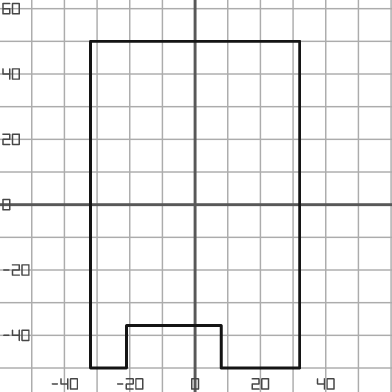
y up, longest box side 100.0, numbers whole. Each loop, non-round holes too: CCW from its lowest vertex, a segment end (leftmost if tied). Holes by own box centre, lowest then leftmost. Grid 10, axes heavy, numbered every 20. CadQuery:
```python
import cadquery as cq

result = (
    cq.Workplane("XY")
    .moveTo(-32.0, -50.0)
    .lineTo(-21.0, -50.0)
    .lineTo(-21.0, -37.0)
    .lineTo(8.0, -37.0)
    .lineTo(8.0, -50.0)
    .lineTo(32.0, -50.0)
    .lineTo(32.0, 50.0)
    .lineTo(-32.0, 50.0)
    .close()
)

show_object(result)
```